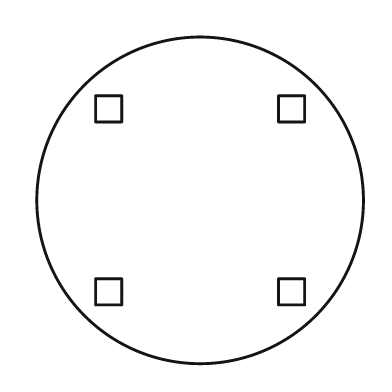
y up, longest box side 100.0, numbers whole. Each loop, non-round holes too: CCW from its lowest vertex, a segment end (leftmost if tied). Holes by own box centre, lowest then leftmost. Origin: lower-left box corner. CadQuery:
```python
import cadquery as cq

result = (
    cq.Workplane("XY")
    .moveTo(50.0, 50.0)
    .circle(50.0)
    .moveTo(18.0, 18.0)
    .lineTo(26.0, 18.0)
    .lineTo(26.0, 26.0)
    .lineTo(18.0, 26.0)
    .close()
    .moveTo(74.0, 18.0)
    .lineTo(82.0, 18.0)
    .lineTo(82.0, 26.0)
    .lineTo(74.0, 26.0)
    .close()
    .moveTo(18.0, 74.0)
    .lineTo(26.0, 74.0)
    .lineTo(26.0, 82.0)
    .lineTo(18.0, 82.0)
    .close()
    .moveTo(74.0, 74.0)
    .lineTo(82.0, 74.0)
    .lineTo(82.0, 82.0)
    .lineTo(74.0, 82.0)
    .close()
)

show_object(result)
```